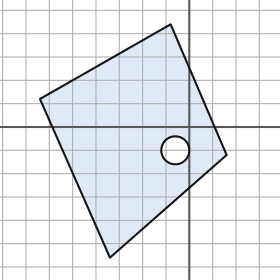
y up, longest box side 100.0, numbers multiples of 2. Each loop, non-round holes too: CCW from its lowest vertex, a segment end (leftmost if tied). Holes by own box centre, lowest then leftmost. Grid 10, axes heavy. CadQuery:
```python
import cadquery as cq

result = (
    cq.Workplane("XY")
    .moveTo(-34.0, -56.0)
    .lineTo(16.0, -12.0)
    .lineTo(-8.0, 44.0)
    .lineTo(-64.0, 12.0)
    .close()
    .moveTo(-6.0, -10.0)
    .circle(6.0)
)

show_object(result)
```